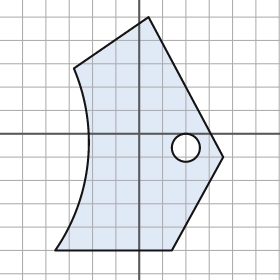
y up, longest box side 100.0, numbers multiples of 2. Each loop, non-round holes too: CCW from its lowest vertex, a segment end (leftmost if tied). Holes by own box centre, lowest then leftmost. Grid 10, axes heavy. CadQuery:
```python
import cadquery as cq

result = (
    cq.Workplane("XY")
    .moveTo(-36.0, -50.0)
    .lineTo(14.0, -50.0)
    .lineTo(36.0, -10.0)
    .lineTo(4.0, 50.0)
    .lineTo(-28.0, 28.0)
    .threePointArc((-22.0, -12.0), (-36.0, -50.0))
    .close()
    .moveTo(20.0, -6.0)
    .circle(6.0)
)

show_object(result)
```